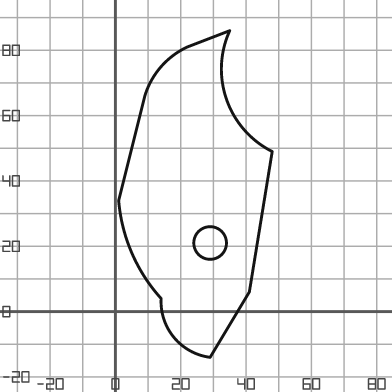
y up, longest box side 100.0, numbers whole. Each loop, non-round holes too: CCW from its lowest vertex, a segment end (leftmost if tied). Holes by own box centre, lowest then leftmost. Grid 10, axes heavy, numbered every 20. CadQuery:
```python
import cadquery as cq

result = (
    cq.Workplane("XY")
    .moveTo(29.0, -14.0)
    .lineTo(41.0, 6.0)
    .lineTo(48.0, 49.0)
    .threePointArc((34.0, 65.0), (35.0, 86.0))
    .lineTo(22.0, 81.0)
    .threePointArc((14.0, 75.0), (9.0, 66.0))
    .lineTo(1.0, 34.0)
    .threePointArc((5.0, 18.0), (14.0, 4.0))
    .threePointArc((18.0, -8.0), (29.0, -14.0))
    .close()
    .moveTo(29.0, 21.0)
    .circle(5.0)
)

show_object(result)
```